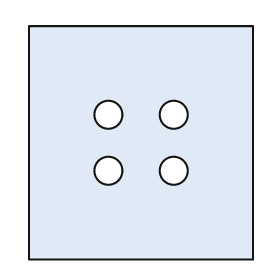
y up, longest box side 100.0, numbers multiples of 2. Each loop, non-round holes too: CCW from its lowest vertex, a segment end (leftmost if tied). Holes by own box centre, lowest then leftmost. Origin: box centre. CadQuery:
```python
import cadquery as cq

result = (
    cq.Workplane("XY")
    .moveTo(-48.0, -50.0)
    .lineTo(48.0, -50.0)
    .lineTo(48.0, 50.0)
    .lineTo(-48.0, 50.0)
    .close()
    .moveTo(-14.0, -12.0)
    .circle(6.0)
    .moveTo(14.0, -12.0)
    .circle(6.0)
    .moveTo(-14.0, 12.0)
    .circle(6.0)
    .moveTo(14.0, 12.0)
    .circle(6.0)
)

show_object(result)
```